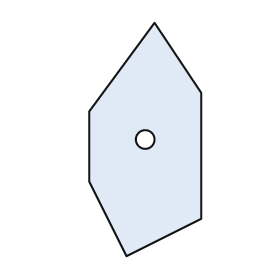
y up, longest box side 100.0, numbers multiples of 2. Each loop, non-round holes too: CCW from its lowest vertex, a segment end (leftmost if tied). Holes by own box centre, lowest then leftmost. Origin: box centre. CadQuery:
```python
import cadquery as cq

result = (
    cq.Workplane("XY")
    .moveTo(-8.0, -50.0)
    .lineTo(24.0, -34.0)
    .lineTo(24.0, 20.0)
    .lineTo(4.0, 50.0)
    .lineTo(-24.0, 12.0)
    .lineTo(-24.0, -18.0)
    .close()
    .moveTo(0.0, 0.0)
    .circle(4.0)
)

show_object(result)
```